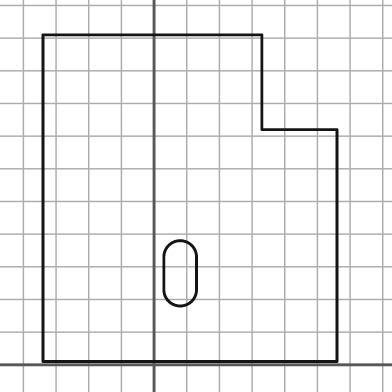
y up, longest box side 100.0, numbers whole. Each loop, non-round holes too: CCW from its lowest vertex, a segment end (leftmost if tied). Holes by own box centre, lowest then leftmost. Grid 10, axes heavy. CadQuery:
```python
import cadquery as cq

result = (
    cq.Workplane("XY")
    .moveTo(-34.0, 1.0)
    .lineTo(56.0, 1.0)
    .lineTo(56.0, 72.0)
    .lineTo(33.0, 72.0)
    .lineTo(33.0, 101.0)
    .lineTo(-34.0, 101.0)
    .close()
    .moveTo(3.0, 23.0)
    .threePointArc((8.0, 18.0), (13.0, 23.0))
    .lineTo(13.0, 33.0)
    .threePointArc((8.0, 38.0), (3.0, 33.0))
    .close()
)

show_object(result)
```